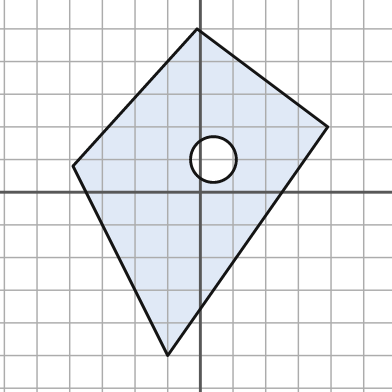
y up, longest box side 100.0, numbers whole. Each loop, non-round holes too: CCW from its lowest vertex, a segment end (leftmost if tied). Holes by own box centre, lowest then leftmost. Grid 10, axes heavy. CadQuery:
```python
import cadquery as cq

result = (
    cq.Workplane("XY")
    .moveTo(-10.0, -50.0)
    .lineTo(39.0, 20.0)
    .lineTo(-1.0, 50.0)
    .lineTo(-39.0, 8.0)
    .close()
    .moveTo(4.0, 10.0)
    .circle(7.0)
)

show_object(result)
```